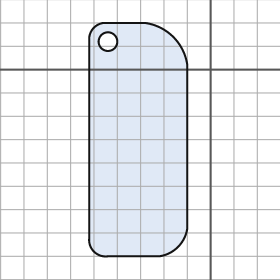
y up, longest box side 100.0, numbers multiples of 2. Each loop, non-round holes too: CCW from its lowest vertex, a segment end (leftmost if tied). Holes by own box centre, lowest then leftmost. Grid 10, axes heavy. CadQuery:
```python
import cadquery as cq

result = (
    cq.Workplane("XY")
    .moveTo(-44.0, -80.0)
    .lineTo(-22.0, -80.0)
    .threePointArc((-14.0, -76.0), (-10.0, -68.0))
    .lineTo(-10.0, 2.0)
    .threePointArc((-16.0, 14.0), (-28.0, 20.0))
    .lineTo(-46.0, 20.0)
    .threePointArc((-50.0, 18.0), (-52.0, 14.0))
    .lineTo(-52.0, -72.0)
    .threePointArc((-50.0, -78.0), (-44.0, -80.0))
    .close()
    .moveTo(-44.0, 12.0)
    .circle(4.0)
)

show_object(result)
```